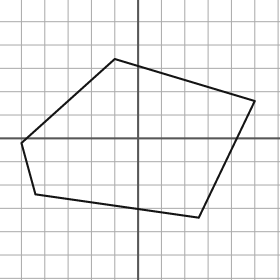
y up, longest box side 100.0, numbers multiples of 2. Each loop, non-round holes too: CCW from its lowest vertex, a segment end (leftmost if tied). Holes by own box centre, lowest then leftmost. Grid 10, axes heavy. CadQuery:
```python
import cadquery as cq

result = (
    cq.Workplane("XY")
    .moveTo(26.0, -34.0)
    .lineTo(50.0, 16.0)
    .lineTo(-10.0, 34.0)
    .lineTo(-50.0, -2.0)
    .lineTo(-44.0, -24.0)
    .close()
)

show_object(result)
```